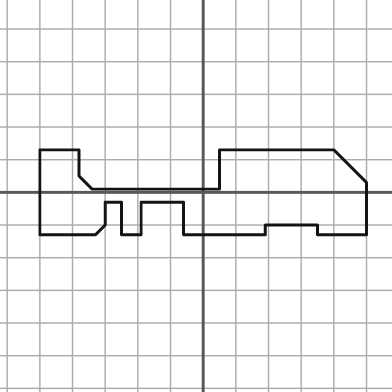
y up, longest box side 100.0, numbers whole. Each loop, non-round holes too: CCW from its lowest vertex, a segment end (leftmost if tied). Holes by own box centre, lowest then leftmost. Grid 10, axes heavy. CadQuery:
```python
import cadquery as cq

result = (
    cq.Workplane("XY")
    .moveTo(-50.0, -13.0)
    .lineTo(-33.0, -13.0)
    .lineTo(-30.0, -10.0)
    .lineTo(-30.0, -3.0)
    .lineTo(-25.0, -3.0)
    .lineTo(-25.0, -13.0)
    .lineTo(-19.0, -13.0)
    .lineTo(-19.0, -3.0)
    .lineTo(-6.0, -3.0)
    .lineTo(-6.0, -13.0)
    .lineTo(19.0, -13.0)
    .lineTo(19.0, -10.0)
    .lineTo(35.0, -10.0)
    .lineTo(35.0, -13.0)
    .lineTo(50.0, -13.0)
    .lineTo(50.0, 3.0)
    .lineTo(40.0, 13.0)
    .lineTo(5.0, 13.0)
    .lineTo(5.0, 1.0)
    .lineTo(-34.0, 1.0)
    .lineTo(-38.0, 5.0)
    .lineTo(-38.0, 13.0)
    .lineTo(-50.0, 13.0)
    .close()
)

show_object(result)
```